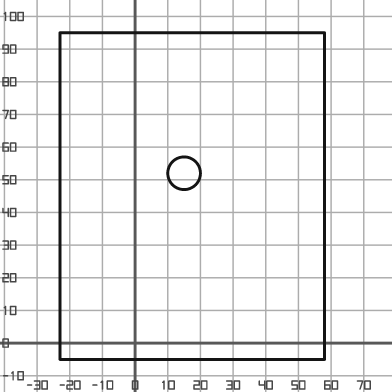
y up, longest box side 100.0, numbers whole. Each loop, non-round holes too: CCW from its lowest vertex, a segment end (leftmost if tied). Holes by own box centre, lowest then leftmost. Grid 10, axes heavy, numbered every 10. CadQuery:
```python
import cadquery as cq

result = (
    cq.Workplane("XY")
    .moveTo(-23.0, -5.0)
    .lineTo(58.0, -5.0)
    .lineTo(58.0, 95.0)
    .lineTo(-23.0, 95.0)
    .close()
    .moveTo(15.0, 52.0)
    .circle(5.0)
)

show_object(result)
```